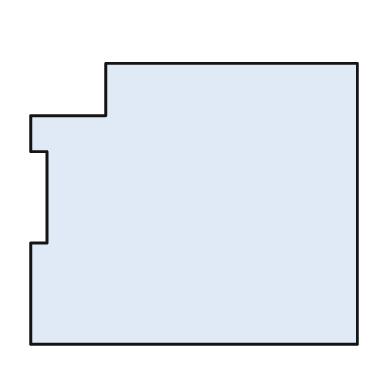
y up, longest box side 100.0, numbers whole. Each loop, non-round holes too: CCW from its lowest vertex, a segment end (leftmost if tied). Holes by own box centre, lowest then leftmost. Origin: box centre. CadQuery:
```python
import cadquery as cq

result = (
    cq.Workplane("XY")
    .moveTo(-50.0, -43.0)
    .lineTo(50.0, -43.0)
    .lineTo(50.0, 43.0)
    .lineTo(-27.0, 43.0)
    .lineTo(-27.0, 27.0)
    .lineTo(-50.0, 27.0)
    .lineTo(-50.0, 16.0)
    .lineTo(-45.0, 16.0)
    .lineTo(-45.0, -12.0)
    .lineTo(-50.0, -12.0)
    .close()
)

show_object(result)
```